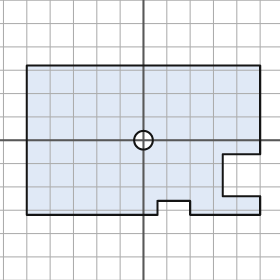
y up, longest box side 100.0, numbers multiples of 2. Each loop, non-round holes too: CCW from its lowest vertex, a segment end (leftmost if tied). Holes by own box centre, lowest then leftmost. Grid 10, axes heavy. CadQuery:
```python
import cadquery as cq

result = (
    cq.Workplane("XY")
    .moveTo(-50.0, -32.0)
    .lineTo(6.0, -32.0)
    .lineTo(6.0, -26.0)
    .lineTo(20.0, -26.0)
    .lineTo(20.0, -32.0)
    .lineTo(50.0, -32.0)
    .lineTo(50.0, -24.0)
    .lineTo(34.0, -24.0)
    .lineTo(34.0, -6.0)
    .lineTo(50.0, -6.0)
    .lineTo(50.0, 32.0)
    .lineTo(-50.0, 32.0)
    .close()
    .moveTo(0.0, 0.0)
    .circle(4.0)
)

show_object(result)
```